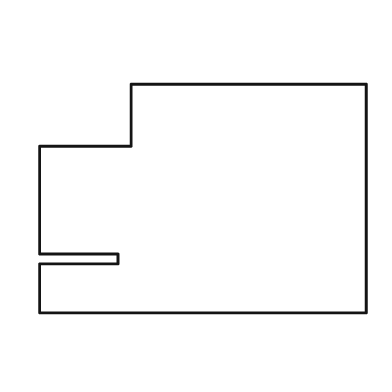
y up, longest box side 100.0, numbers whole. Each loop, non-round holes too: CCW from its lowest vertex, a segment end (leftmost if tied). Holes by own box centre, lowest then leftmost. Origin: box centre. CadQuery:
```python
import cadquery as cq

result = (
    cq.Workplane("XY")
    .moveTo(-50.0, -35.0)
    .lineTo(50.0, -35.0)
    .lineTo(50.0, 35.0)
    .lineTo(-22.0, 35.0)
    .lineTo(-22.0, 16.0)
    .lineTo(-50.0, 16.0)
    .lineTo(-50.0, -17.0)
    .lineTo(-26.0, -17.0)
    .lineTo(-26.0, -20.0)
    .lineTo(-50.0, -20.0)
    .close()
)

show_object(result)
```